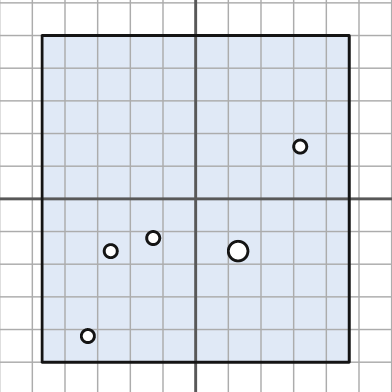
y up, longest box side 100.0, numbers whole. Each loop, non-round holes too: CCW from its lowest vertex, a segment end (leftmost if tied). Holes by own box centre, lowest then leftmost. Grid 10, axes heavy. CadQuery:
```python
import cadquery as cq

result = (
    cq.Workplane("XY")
    .moveTo(-47.0, -50.0)
    .lineTo(47.0, -50.0)
    .lineTo(47.0, 50.0)
    .lineTo(-47.0, 50.0)
    .close()
    .moveTo(-33.0, -42.0)
    .circle(2.0)
    .moveTo(-26.0, -16.0)
    .circle(2.0)
    .moveTo(13.0, -16.0)
    .circle(3.0)
    .moveTo(-13.0, -12.0)
    .circle(2.0)
    .moveTo(32.0, 16.0)
    .circle(2.0)
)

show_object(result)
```